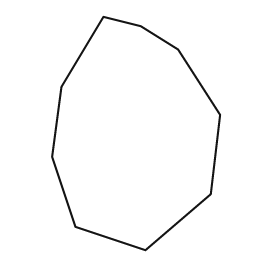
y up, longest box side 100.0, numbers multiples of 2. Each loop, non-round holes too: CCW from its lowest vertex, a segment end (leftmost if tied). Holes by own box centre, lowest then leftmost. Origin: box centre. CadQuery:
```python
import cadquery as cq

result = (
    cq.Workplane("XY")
    .moveTo(4.0, -50.0)
    .lineTo(32.0, -26.0)
    .lineTo(36.0, 8.0)
    .lineTo(18.0, 36.0)
    .lineTo(2.0, 46.0)
    .lineTo(-14.0, 50.0)
    .lineTo(-32.0, 20.0)
    .lineTo(-36.0, -10.0)
    .lineTo(-26.0, -40.0)
    .close()
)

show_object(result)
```